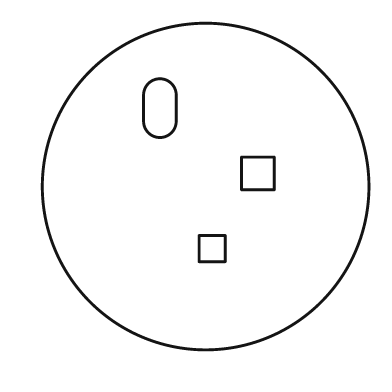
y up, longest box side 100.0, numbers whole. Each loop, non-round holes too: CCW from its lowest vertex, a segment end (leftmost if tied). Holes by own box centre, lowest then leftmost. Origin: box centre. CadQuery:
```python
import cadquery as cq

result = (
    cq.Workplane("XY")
    .moveTo(0.0, 0.0)
    .circle(50.0)
    .moveTo(-2.0, -23.0)
    .lineTo(6.0, -23.0)
    .lineTo(6.0, -15.0)
    .lineTo(-2.0, -15.0)
    .close()
    .moveTo(11.0, -1.0)
    .lineTo(21.0, -1.0)
    .lineTo(21.0, 9.0)
    .lineTo(11.0, 9.0)
    .close()
    .moveTo(-19.0, 20.0)
    .threePointArc((-14.0, 15.0), (-9.0, 20.0))
    .lineTo(-9.0, 28.0)
    .threePointArc((-14.0, 33.0), (-19.0, 28.0))
    .close()
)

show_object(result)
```